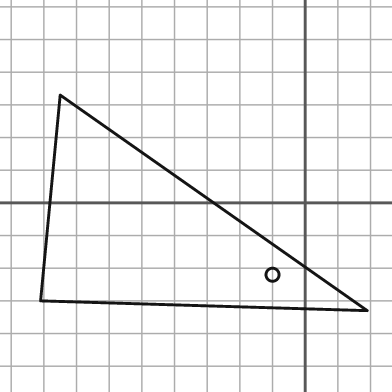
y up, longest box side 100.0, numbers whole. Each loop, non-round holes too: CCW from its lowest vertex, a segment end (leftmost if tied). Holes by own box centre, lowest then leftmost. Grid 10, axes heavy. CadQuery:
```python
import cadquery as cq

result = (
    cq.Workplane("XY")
    .moveTo(19.0, -33.0)
    .lineTo(-75.0, 33.0)
    .lineTo(-81.0, -30.0)
    .close()
    .moveTo(-10.0, -22.0)
    .circle(2.0)
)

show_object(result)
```